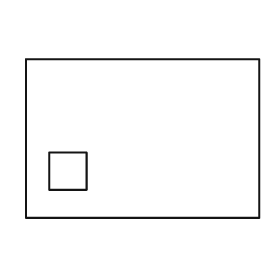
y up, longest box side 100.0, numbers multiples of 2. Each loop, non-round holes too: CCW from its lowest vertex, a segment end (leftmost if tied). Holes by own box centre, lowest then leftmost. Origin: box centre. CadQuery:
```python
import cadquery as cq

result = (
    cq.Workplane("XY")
    .moveTo(-50.0, -34.0)
    .lineTo(50.0, -34.0)
    .lineTo(50.0, 34.0)
    .lineTo(-50.0, 34.0)
    .close()
    .moveTo(-40.0, -22.0)
    .lineTo(-24.0, -22.0)
    .lineTo(-24.0, -6.0)
    .lineTo(-40.0, -6.0)
    .close()
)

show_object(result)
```